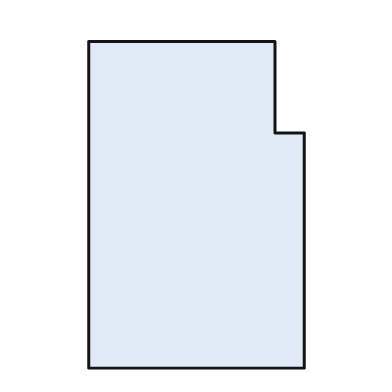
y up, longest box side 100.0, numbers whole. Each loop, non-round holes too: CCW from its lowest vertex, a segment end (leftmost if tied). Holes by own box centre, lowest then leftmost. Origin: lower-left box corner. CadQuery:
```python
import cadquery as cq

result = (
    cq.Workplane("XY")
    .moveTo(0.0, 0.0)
    .lineTo(66.0, 0.0)
    .lineTo(66.0, 72.0)
    .lineTo(57.0, 72.0)
    .lineTo(57.0, 100.0)
    .lineTo(0.0, 100.0)
    .close()
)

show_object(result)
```